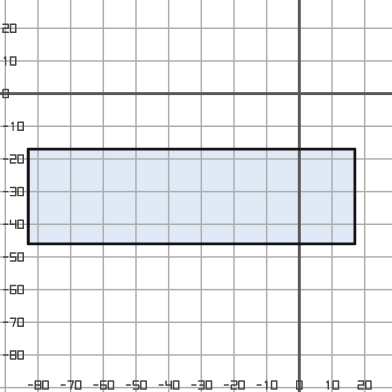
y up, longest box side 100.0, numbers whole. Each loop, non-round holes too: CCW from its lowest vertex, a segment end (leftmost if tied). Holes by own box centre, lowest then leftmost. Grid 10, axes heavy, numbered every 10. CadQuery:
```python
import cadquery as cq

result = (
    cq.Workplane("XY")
    .moveTo(-83.0, -46.0)
    .lineTo(17.0, -46.0)
    .lineTo(17.0, -17.0)
    .lineTo(-83.0, -17.0)
    .close()
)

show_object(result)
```